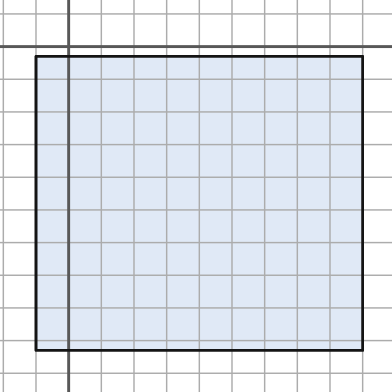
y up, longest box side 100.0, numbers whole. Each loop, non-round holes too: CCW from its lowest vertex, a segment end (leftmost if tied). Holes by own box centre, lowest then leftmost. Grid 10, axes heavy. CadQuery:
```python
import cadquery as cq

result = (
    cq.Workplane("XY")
    .moveTo(-10.0, -93.0)
    .lineTo(90.0, -93.0)
    .lineTo(90.0, -3.0)
    .lineTo(-10.0, -3.0)
    .close()
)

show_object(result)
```